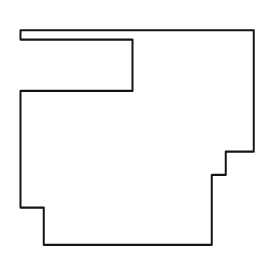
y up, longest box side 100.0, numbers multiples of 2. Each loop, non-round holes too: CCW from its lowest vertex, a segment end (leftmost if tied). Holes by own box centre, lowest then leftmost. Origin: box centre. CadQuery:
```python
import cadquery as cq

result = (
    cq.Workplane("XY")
    .moveTo(-40.0, -46.0)
    .lineTo(32.0, -46.0)
    .lineTo(32.0, -16.0)
    .lineTo(38.0, -16.0)
    .lineTo(38.0, -6.0)
    .lineTo(50.0, -6.0)
    .lineTo(50.0, 46.0)
    .lineTo(-50.0, 46.0)
    .lineTo(-50.0, 42.0)
    .lineTo(-2.0, 42.0)
    .lineTo(-2.0, 20.0)
    .lineTo(-50.0, 20.0)
    .lineTo(-50.0, -30.0)
    .lineTo(-40.0, -30.0)
    .close()
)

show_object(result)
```